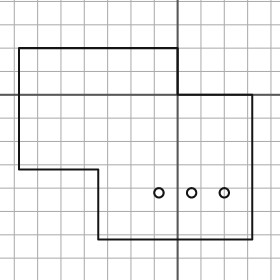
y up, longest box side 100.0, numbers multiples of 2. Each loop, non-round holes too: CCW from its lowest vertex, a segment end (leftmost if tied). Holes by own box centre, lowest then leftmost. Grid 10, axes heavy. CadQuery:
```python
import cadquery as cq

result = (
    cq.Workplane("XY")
    .moveTo(-34.0, -62.0)
    .lineTo(32.0, -62.0)
    .lineTo(32.0, 0.0)
    .lineTo(0.0, 0.0)
    .lineTo(0.0, 20.0)
    .lineTo(-68.0, 20.0)
    .lineTo(-68.0, -32.0)
    .lineTo(-34.0, -32.0)
    .close()
    .moveTo(-8.0, -42.0)
    .circle(2.0)
    .moveTo(6.0, -42.0)
    .circle(2.0)
    .moveTo(20.0, -42.0)
    .circle(2.0)
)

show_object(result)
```